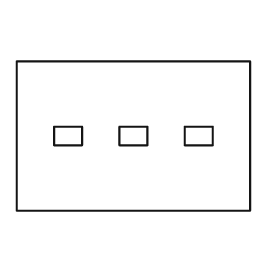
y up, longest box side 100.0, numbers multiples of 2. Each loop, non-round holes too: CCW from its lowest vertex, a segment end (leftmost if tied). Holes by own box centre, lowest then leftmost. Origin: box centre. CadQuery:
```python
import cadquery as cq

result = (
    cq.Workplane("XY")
    .moveTo(-50.0, -32.0)
    .lineTo(50.0, -32.0)
    .lineTo(50.0, 32.0)
    .lineTo(-50.0, 32.0)
    .close()
    .moveTo(-34.0, -4.0)
    .lineTo(-22.0, -4.0)
    .lineTo(-22.0, 4.0)
    .lineTo(-34.0, 4.0)
    .close()
    .moveTo(-6.0, -4.0)
    .lineTo(6.0, -4.0)
    .lineTo(6.0, 4.0)
    .lineTo(-6.0, 4.0)
    .close()
    .moveTo(22.0, -4.0)
    .lineTo(34.0, -4.0)
    .lineTo(34.0, 4.0)
    .lineTo(22.0, 4.0)
    .close()
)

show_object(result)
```